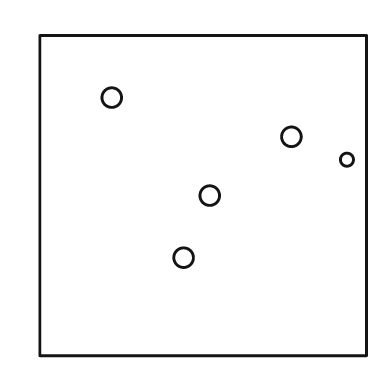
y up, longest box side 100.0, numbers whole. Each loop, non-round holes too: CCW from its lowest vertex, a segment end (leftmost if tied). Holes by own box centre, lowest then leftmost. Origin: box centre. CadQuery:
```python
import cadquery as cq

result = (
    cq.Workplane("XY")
    .moveTo(-50.0, -49.0)
    .lineTo(50.0, -49.0)
    .lineTo(50.0, 49.0)
    .lineTo(-50.0, 49.0)
    .close()
    .moveTo(-6.0, -19.0)
    .circle(3.0)
    .moveTo(2.0, 0.0)
    .circle(3.0)
    .moveTo(44.0, 11.0)
    .circle(2.0)
    .moveTo(27.0, 18.0)
    .circle(3.0)
    .moveTo(-28.0, 30.0)
    .circle(3.0)
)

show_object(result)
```